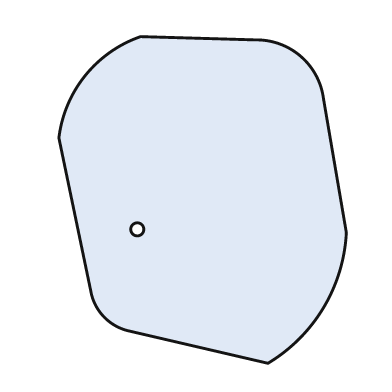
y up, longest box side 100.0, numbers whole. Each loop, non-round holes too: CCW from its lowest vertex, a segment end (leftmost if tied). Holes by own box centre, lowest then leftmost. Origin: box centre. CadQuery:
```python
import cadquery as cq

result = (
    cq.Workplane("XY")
    .moveTo(20.0, -50.0)
    .threePointArc((37.0, -33.0), (44.0, -10.0))
    .lineTo(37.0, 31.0)
    .threePointArc((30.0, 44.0), (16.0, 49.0))
    .lineTo(-19.0, 50.0)
    .threePointArc((-36.0, 38.0), (-44.0, 19.0))
    .lineTo(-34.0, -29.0)
    .threePointArc((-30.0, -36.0), (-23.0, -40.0))
    .close()
    .moveTo(-20.0, -9.0)
    .circle(2.0)
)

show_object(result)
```